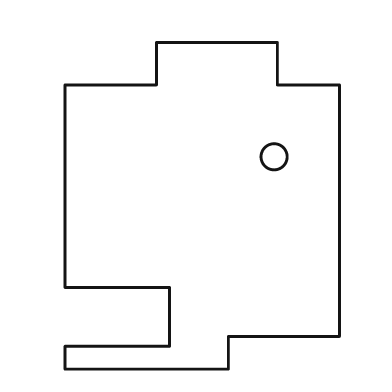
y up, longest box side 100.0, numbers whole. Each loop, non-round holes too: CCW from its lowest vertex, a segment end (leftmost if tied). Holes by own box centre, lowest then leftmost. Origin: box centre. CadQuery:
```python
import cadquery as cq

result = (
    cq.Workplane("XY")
    .moveTo(-42.0, -50.0)
    .lineTo(8.0, -50.0)
    .lineTo(8.0, -40.0)
    .lineTo(42.0, -40.0)
    .lineTo(42.0, 37.0)
    .lineTo(23.0, 37.0)
    .lineTo(23.0, 50.0)
    .lineTo(-14.0, 50.0)
    .lineTo(-14.0, 37.0)
    .lineTo(-42.0, 37.0)
    .lineTo(-42.0, -25.0)
    .lineTo(-10.0, -25.0)
    .lineTo(-10.0, -43.0)
    .lineTo(-42.0, -43.0)
    .close()
    .moveTo(22.0, 15.0)
    .circle(4.0)
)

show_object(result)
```